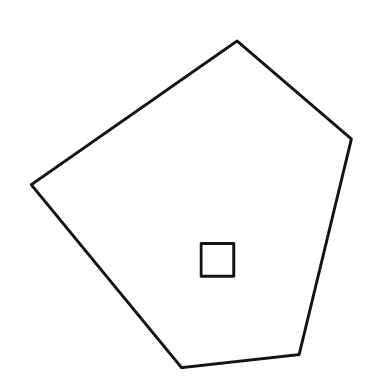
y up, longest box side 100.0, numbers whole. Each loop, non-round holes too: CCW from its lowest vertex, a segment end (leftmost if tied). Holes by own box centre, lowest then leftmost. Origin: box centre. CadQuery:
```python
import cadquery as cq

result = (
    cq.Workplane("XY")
    .moveTo(-3.0, -50.0)
    .lineTo(33.0, -46.0)
    .lineTo(49.0, 20.0)
    .lineTo(14.0, 50.0)
    .lineTo(-49.0, 6.0)
    .close()
    .moveTo(3.0, -22.0)
    .lineTo(13.0, -22.0)
    .lineTo(13.0, -12.0)
    .lineTo(3.0, -12.0)
    .close()
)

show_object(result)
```